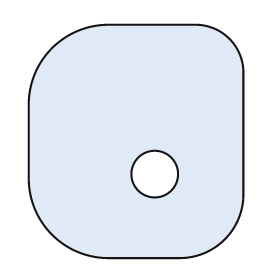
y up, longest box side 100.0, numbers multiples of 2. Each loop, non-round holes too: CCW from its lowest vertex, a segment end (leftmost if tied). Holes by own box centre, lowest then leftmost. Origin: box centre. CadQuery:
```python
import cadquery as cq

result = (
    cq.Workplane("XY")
    .moveTo(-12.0, -50.0)
    .lineTo(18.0, -50.0)
    .threePointArc((38.0, -42.0), (46.0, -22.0))
    .lineTo(46.0, 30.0)
    .threePointArc((40.0, 44.0), (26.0, 50.0))
    .lineTo(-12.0, 50.0)
    .threePointArc((-36.0, 40.0), (-46.0, 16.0))
    .lineTo(-46.0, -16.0)
    .threePointArc((-36.0, -40.0), (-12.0, -50.0))
    .close()
    .moveTo(8.0, -14.0)
    .circle(10.0)
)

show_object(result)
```